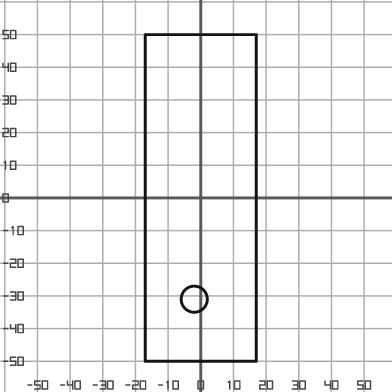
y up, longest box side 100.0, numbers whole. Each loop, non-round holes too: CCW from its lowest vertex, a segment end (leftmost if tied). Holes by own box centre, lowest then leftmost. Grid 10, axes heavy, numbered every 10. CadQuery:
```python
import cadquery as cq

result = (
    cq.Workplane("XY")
    .moveTo(-17.0, -50.0)
    .lineTo(17.0, -50.0)
    .lineTo(17.0, 50.0)
    .lineTo(-17.0, 50.0)
    .close()
    .moveTo(-2.0, -31.0)
    .circle(4.0)
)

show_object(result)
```